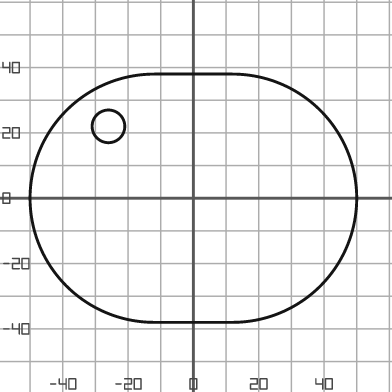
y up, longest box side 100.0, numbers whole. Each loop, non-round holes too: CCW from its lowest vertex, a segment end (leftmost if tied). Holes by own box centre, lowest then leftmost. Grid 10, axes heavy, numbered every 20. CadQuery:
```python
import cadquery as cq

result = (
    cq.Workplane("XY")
    .moveTo(-12.0, -38.0)
    .lineTo(12.0, -38.0)
    .threePointArc((50.0, 0.0), (12.0, 38.0))
    .lineTo(-12.0, 38.0)
    .threePointArc((-50.0, 0.0), (-12.0, -38.0))
    .close()
    .moveTo(-26.0, 22.0)
    .circle(5.0)
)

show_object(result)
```